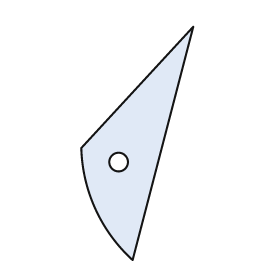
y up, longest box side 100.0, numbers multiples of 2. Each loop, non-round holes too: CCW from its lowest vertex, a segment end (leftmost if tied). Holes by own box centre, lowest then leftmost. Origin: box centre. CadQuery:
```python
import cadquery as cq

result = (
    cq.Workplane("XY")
    .moveTo(-2.0, -50.0)
    .lineTo(24.0, 50.0)
    .lineTo(-24.0, -2.0)
    .threePointArc((-18.0, -28.0), (-2.0, -50.0))
    .close()
    .moveTo(-8.0, -8.0)
    .circle(4.0)
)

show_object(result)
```